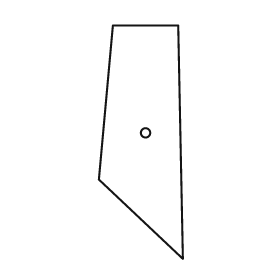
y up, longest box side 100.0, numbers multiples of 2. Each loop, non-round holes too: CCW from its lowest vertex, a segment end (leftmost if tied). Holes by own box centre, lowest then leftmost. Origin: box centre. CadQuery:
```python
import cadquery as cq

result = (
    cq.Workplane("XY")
    .moveTo(18.0, -50.0)
    .lineTo(16.0, 50.0)
    .lineTo(-12.0, 50.0)
    .lineTo(-18.0, -16.0)
    .close()
    .moveTo(2.0, 4.0)
    .circle(2.0)
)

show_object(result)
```